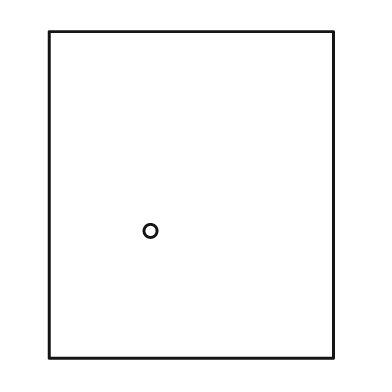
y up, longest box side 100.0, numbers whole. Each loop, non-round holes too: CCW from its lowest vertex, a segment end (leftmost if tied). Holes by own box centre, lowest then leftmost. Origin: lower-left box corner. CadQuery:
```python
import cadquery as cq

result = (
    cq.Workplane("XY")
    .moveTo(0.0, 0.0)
    .lineTo(87.0, 0.0)
    .lineTo(87.0, 100.0)
    .lineTo(0.0, 100.0)
    .close()
    .moveTo(31.0, 39.0)
    .circle(2.0)
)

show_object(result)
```